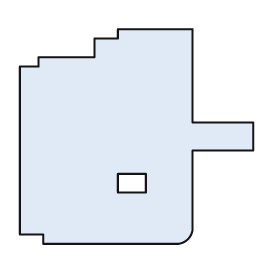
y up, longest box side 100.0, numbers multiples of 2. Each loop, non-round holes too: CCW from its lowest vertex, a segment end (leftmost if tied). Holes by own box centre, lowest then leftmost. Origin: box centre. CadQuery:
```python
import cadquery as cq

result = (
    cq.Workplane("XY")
    .moveTo(-40.0, -46.0)
    .lineTo(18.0, -46.0)
    .threePointArc((22.0, -44.0), (24.0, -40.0))
    .lineTo(24.0, -6.0)
    .lineTo(50.0, -6.0)
    .lineTo(50.0, 6.0)
    .lineTo(24.0, 6.0)
    .lineTo(24.0, 46.0)
    .lineTo(-8.0, 46.0)
    .lineTo(-8.0, 42.0)
    .lineTo(-18.0, 42.0)
    .lineTo(-18.0, 34.0)
    .lineTo(-42.0, 34.0)
    .lineTo(-42.0, 30.0)
    .lineTo(-50.0, 30.0)
    .lineTo(-50.0, -42.0)
    .lineTo(-40.0, -42.0)
    .close()
    .moveTo(-8.0, -24.0)
    .lineTo(4.0, -24.0)
    .lineTo(4.0, -16.0)
    .lineTo(-8.0, -16.0)
    .close()
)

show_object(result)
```